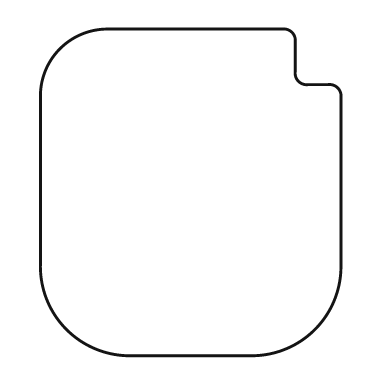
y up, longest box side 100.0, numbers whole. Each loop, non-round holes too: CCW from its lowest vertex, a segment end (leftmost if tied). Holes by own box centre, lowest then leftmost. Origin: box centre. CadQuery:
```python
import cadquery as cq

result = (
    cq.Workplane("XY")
    .moveTo(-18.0, -50.0)
    .lineTo(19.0, -50.0)
    .threePointArc((38.0, -42.0), (46.0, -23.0))
    .lineTo(46.0, 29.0)
    .threePointArc((45.0, 32.0), (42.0, 33.0))
    .lineTo(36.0, 33.0)
    .threePointArc((33.0, 34.0), (32.0, 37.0))
    .lineTo(32.0, 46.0)
    .threePointArc((31.0, 49.0), (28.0, 50.0))
    .lineTo(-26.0, 50.0)
    .threePointArc((-40.0, 44.0), (-46.0, 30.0))
    .lineTo(-46.0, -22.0)
    .threePointArc((-38.0, -42.0), (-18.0, -50.0))
    .close()
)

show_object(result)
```